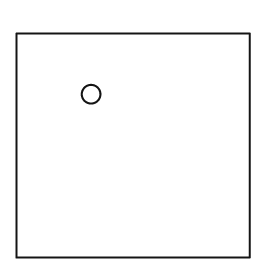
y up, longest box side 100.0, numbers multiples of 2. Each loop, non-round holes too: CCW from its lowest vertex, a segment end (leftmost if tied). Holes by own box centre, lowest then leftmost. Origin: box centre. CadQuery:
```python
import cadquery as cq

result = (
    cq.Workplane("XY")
    .moveTo(-50.0, -48.0)
    .lineTo(50.0, -48.0)
    .lineTo(50.0, 48.0)
    .lineTo(-50.0, 48.0)
    .close()
    .moveTo(-18.0, 22.0)
    .circle(4.0)
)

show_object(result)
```